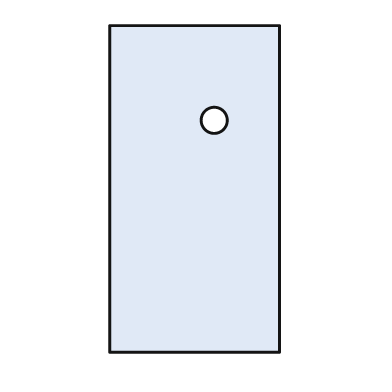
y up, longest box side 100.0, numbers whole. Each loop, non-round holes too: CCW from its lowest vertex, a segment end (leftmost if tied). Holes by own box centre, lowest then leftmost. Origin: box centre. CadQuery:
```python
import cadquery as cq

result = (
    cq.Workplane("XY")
    .moveTo(-26.0, -50.0)
    .lineTo(26.0, -50.0)
    .lineTo(26.0, 50.0)
    .lineTo(-26.0, 50.0)
    .close()
    .moveTo(6.0, 21.0)
    .circle(4.0)
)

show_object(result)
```